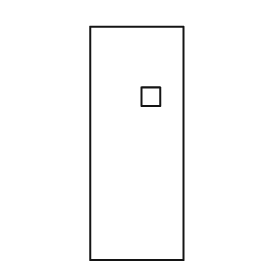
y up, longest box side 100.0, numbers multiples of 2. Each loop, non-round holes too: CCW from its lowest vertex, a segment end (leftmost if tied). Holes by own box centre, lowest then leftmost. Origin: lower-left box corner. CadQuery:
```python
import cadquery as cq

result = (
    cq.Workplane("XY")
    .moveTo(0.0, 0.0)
    .lineTo(40.0, 0.0)
    .lineTo(40.0, 100.0)
    .lineTo(0.0, 100.0)
    .close()
    .moveTo(22.0, 66.0)
    .lineTo(30.0, 66.0)
    .lineTo(30.0, 74.0)
    .lineTo(22.0, 74.0)
    .close()
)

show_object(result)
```